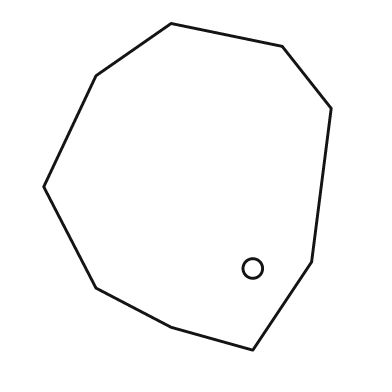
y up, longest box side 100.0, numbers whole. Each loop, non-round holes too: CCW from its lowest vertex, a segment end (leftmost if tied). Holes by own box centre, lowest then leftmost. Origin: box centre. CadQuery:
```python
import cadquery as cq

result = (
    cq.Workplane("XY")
    .moveTo(20.0, -50.0)
    .lineTo(38.0, -23.0)
    .lineTo(44.0, 24.0)
    .lineTo(29.0, 43.0)
    .lineTo(-5.0, 50.0)
    .lineTo(-28.0, 34.0)
    .lineTo(-44.0, 0.0)
    .lineTo(-28.0, -31.0)
    .lineTo(-5.0, -43.0)
    .close()
    .moveTo(20.0, -25.0)
    .circle(3.0)
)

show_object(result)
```